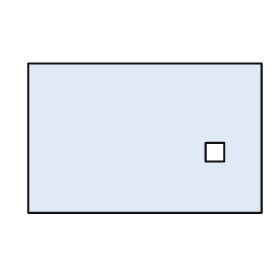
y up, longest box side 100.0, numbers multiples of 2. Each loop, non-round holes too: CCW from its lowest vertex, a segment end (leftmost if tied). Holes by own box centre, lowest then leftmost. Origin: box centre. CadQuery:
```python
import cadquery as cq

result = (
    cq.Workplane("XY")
    .moveTo(-50.0, -32.0)
    .lineTo(50.0, -32.0)
    .lineTo(50.0, 32.0)
    .lineTo(-50.0, 32.0)
    .close()
    .moveTo(26.0, -10.0)
    .lineTo(34.0, -10.0)
    .lineTo(34.0, -2.0)
    .lineTo(26.0, -2.0)
    .close()
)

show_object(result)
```